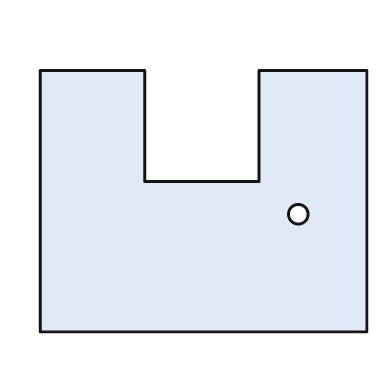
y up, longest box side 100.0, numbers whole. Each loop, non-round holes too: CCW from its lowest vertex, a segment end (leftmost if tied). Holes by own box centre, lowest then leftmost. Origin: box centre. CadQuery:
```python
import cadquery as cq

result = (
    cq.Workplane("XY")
    .moveTo(-50.0, -40.0)
    .lineTo(50.0, -40.0)
    .lineTo(50.0, 40.0)
    .lineTo(17.0, 40.0)
    .lineTo(17.0, 6.0)
    .lineTo(-18.0, 6.0)
    .lineTo(-18.0, 40.0)
    .lineTo(-50.0, 40.0)
    .close()
    .moveTo(29.0, -4.0)
    .circle(3.0)
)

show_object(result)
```